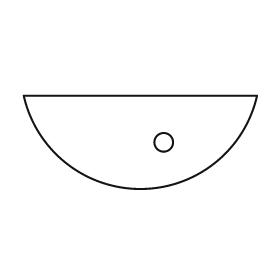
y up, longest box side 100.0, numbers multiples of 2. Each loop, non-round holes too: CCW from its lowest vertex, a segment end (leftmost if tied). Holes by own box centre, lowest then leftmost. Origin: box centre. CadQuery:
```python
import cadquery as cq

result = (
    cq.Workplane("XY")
    .moveTo(-50.0, 20.0)
    .threePointArc((0.0, -20.0), (50.0, 20.0))
    .close()
    .moveTo(10.0, 0.0)
    .circle(4.0)
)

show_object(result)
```